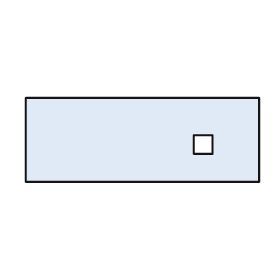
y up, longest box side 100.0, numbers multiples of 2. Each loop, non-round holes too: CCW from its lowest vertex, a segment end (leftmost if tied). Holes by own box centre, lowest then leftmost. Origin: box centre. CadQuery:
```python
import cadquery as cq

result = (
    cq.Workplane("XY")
    .moveTo(-50.0, -18.0)
    .lineTo(50.0, -18.0)
    .lineTo(50.0, 18.0)
    .lineTo(-50.0, 18.0)
    .close()
    .moveTo(22.0, -6.0)
    .lineTo(30.0, -6.0)
    .lineTo(30.0, 2.0)
    .lineTo(22.0, 2.0)
    .close()
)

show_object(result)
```